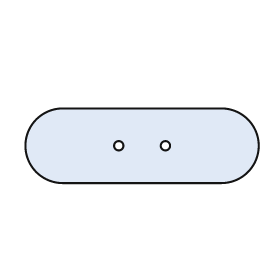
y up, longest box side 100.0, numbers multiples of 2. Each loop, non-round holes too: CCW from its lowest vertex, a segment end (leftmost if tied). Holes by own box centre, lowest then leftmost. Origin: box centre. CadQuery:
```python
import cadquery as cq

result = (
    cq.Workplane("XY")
    .moveTo(-34.0, -16.0)
    .lineTo(34.0, -16.0)
    .threePointArc((50.0, 0.0), (34.0, 16.0))
    .lineTo(-34.0, 16.0)
    .threePointArc((-50.0, 0.0), (-34.0, -16.0))
    .close()
    .moveTo(-10.0, 0.0)
    .circle(2.0)
    .moveTo(10.0, 0.0)
    .circle(2.0)
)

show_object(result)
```